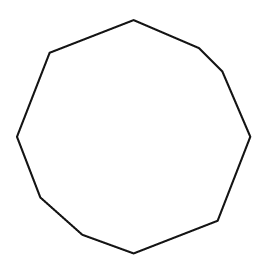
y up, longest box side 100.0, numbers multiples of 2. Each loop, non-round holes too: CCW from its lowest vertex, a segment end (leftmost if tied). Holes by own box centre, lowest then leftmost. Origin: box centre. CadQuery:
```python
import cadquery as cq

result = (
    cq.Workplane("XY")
    .moveTo(0.0, -50.0)
    .lineTo(36.0, -36.0)
    .lineTo(50.0, 0.0)
    .lineTo(38.0, 28.0)
    .lineTo(28.0, 38.0)
    .lineTo(0.0, 50.0)
    .lineTo(-36.0, 36.0)
    .lineTo(-50.0, 0.0)
    .lineTo(-40.0, -26.0)
    .lineTo(-22.0, -42.0)
    .close()
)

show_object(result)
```